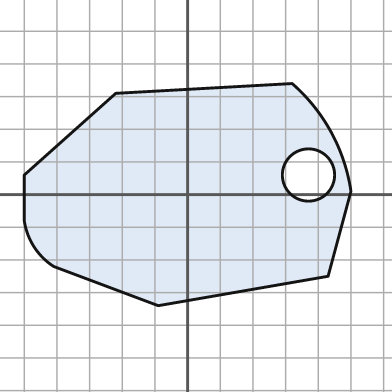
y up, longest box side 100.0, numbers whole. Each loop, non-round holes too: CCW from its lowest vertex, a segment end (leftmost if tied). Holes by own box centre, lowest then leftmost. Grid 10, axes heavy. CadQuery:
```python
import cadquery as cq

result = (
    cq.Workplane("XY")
    .moveTo(-9.0, -34.0)
    .lineTo(43.0, -25.0)
    .lineTo(50.0, 1.0)
    .threePointArc((44.0, 19.0), (32.0, 34.0))
    .lineTo(-22.0, 31.0)
    .lineTo(-50.0, 6.0)
    .lineTo(-50.0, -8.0)
    .threePointArc((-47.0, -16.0), (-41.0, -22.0))
    .close()
    .moveTo(37.0, 6.0)
    .circle(8.0)
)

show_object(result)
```